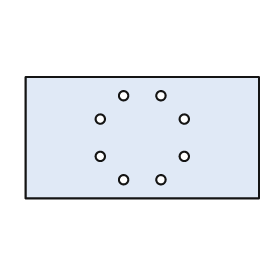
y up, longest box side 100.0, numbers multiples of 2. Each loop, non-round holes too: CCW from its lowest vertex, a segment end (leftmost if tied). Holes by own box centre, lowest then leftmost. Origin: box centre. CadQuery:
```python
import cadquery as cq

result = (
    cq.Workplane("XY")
    .moveTo(-50.0, -26.0)
    .lineTo(50.0, -26.0)
    .lineTo(50.0, 26.0)
    .lineTo(-50.0, 26.0)
    .close()
    .moveTo(-8.0, -18.0)
    .circle(2.0)
    .moveTo(8.0, -18.0)
    .circle(2.0)
    .moveTo(-18.0, -8.0)
    .circle(2.0)
    .moveTo(18.0, -8.0)
    .circle(2.0)
    .moveTo(-18.0, 8.0)
    .circle(2.0)
    .moveTo(18.0, 8.0)
    .circle(2.0)
    .moveTo(-8.0, 18.0)
    .circle(2.0)
    .moveTo(8.0, 18.0)
    .circle(2.0)
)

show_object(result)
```